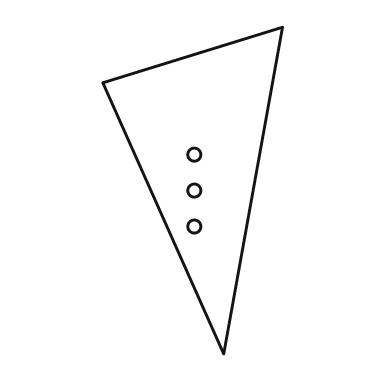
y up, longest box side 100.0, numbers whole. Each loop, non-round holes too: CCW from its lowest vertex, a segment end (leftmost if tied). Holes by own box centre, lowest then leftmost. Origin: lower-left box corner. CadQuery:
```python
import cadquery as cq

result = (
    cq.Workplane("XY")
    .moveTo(37.0, 0.0)
    .lineTo(55.0, 100.0)
    .lineTo(0.0, 83.0)
    .close()
    .moveTo(28.0, 39.0)
    .circle(2.0)
    .moveTo(28.0, 50.0)
    .circle(2.0)
    .moveTo(28.0, 61.0)
    .circle(2.0)
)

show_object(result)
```